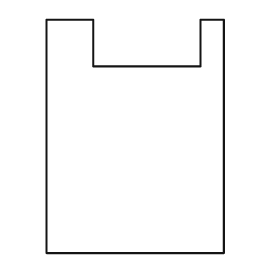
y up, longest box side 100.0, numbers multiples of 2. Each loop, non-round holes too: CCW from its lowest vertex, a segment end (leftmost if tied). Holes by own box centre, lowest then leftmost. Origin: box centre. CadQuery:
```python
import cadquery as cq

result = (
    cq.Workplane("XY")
    .moveTo(-38.0, -50.0)
    .lineTo(38.0, -50.0)
    .lineTo(38.0, 50.0)
    .lineTo(28.0, 50.0)
    .lineTo(28.0, 30.0)
    .lineTo(-18.0, 30.0)
    .lineTo(-18.0, 50.0)
    .lineTo(-38.0, 50.0)
    .close()
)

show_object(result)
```